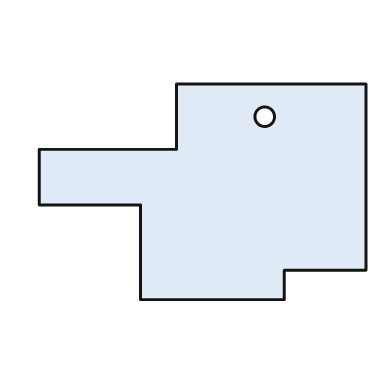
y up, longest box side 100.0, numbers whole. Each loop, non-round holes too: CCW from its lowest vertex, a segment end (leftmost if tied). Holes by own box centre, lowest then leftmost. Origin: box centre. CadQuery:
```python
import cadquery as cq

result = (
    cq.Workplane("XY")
    .moveTo(-19.0, -33.0)
    .lineTo(25.0, -33.0)
    .lineTo(25.0, -24.0)
    .lineTo(50.0, -24.0)
    .lineTo(50.0, 33.0)
    .lineTo(-8.0, 33.0)
    .lineTo(-8.0, 13.0)
    .lineTo(-50.0, 13.0)
    .lineTo(-50.0, -4.0)
    .lineTo(-19.0, -4.0)
    .close()
    .moveTo(19.0, 23.0)
    .circle(3.0)
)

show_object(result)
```